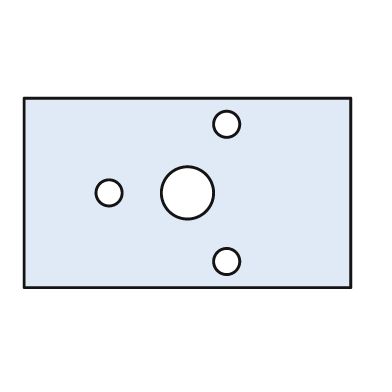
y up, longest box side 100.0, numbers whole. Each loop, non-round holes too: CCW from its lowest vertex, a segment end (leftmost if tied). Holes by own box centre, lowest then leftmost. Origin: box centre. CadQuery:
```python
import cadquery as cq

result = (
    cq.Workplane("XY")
    .moveTo(-50.0, -29.0)
    .lineTo(50.0, -29.0)
    .lineTo(50.0, 29.0)
    .lineTo(-50.0, 29.0)
    .close()
    .moveTo(12.0, -21.0)
    .circle(4.0)
    .moveTo(-24.0, 0.0)
    .circle(4.0)
    .moveTo(0.0, 0.0)
    .circle(8.0)
    .moveTo(12.0, 21.0)
    .circle(4.0)
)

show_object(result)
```